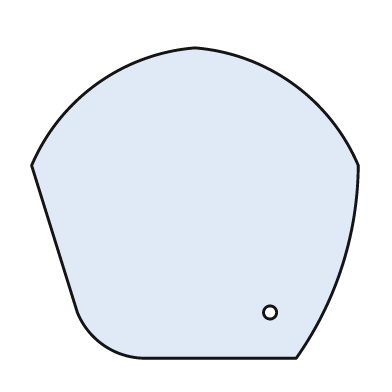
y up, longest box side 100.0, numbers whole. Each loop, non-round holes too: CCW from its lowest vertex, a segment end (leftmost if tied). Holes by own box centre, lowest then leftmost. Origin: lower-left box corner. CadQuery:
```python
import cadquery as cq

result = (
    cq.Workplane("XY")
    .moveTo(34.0, 0.0)
    .lineTo(81.0, 0.0)
    .threePointArc((95.0, 28.0), (100.0, 59.0))
    .threePointArc((80.0, 84.0), (50.0, 95.0))
    .threePointArc((20.0, 84.0), (0.0, 59.0))
    .lineTo(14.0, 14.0)
    .threePointArc((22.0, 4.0), (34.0, 0.0))
    .close()
    .moveTo(73.0, 14.0)
    .circle(2.0)
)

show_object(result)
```